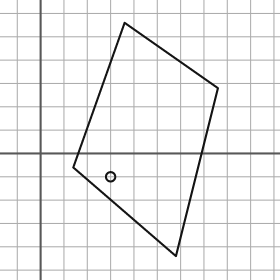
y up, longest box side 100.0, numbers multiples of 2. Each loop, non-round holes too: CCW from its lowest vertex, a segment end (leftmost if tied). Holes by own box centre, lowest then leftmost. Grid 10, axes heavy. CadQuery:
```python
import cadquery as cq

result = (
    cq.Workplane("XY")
    .moveTo(58.0, -44.0)
    .lineTo(76.0, 28.0)
    .lineTo(36.0, 56.0)
    .lineTo(14.0, -6.0)
    .close()
    .moveTo(30.0, -10.0)
    .circle(2.0)
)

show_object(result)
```